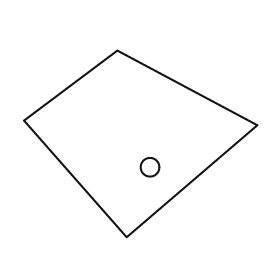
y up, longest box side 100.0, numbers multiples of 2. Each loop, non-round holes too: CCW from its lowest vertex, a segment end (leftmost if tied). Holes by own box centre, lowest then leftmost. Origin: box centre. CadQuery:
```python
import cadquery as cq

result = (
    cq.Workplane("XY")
    .moveTo(-6.0, -40.0)
    .lineTo(50.0, 8.0)
    .lineTo(-10.0, 40.0)
    .lineTo(-50.0, 10.0)
    .close()
    .moveTo(4.0, -10.0)
    .circle(4.0)
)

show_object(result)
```